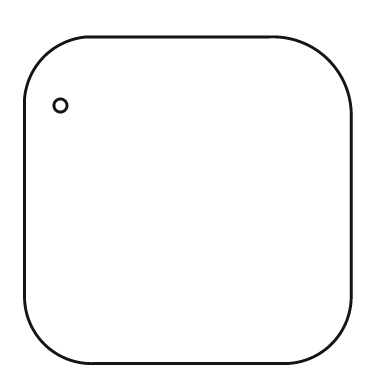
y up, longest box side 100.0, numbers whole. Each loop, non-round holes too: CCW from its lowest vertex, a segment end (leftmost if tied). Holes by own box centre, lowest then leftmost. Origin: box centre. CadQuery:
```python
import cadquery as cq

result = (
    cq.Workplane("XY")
    .moveTo(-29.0, -50.0)
    .lineTo(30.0, -50.0)
    .threePointArc((44.0, -44.0), (50.0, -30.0))
    .lineTo(50.0, 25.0)
    .threePointArc((43.0, 43.0), (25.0, 50.0))
    .lineTo(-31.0, 50.0)
    .threePointArc((-44.0, 44.0), (-50.0, 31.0))
    .lineTo(-50.0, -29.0)
    .threePointArc((-44.0, -44.0), (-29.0, -50.0))
    .close()
    .moveTo(-39.0, 29.0)
    .circle(2.0)
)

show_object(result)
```